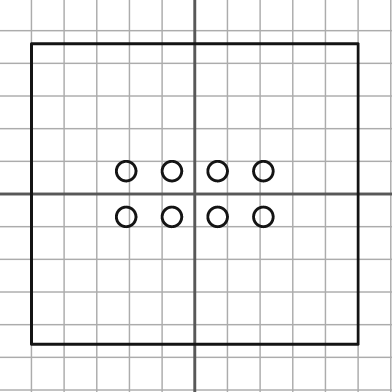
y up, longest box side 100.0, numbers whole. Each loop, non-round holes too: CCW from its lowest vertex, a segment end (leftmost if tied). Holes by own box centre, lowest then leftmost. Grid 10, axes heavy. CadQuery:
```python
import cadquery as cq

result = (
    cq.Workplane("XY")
    .moveTo(-50.0, -46.0)
    .lineTo(50.0, -46.0)
    .lineTo(50.0, 46.0)
    .lineTo(-50.0, 46.0)
    .close()
    .moveTo(-21.0, -7.0)
    .circle(3.0)
    .moveTo(-7.0, -7.0)
    .circle(3.0)
    .moveTo(7.0, -7.0)
    .circle(3.0)
    .moveTo(21.0, -7.0)
    .circle(3.0)
    .moveTo(-21.0, 7.0)
    .circle(3.0)
    .moveTo(-7.0, 7.0)
    .circle(3.0)
    .moveTo(7.0, 7.0)
    .circle(3.0)
    .moveTo(21.0, 7.0)
    .circle(3.0)
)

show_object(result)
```